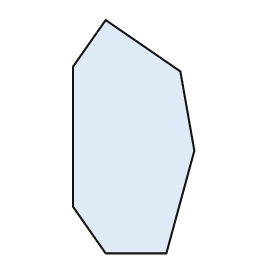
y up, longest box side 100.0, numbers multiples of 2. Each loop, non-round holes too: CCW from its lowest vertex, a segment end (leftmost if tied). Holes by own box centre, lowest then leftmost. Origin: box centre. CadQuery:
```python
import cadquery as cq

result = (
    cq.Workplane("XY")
    .moveTo(-12.0, -50.0)
    .lineTo(14.0, -50.0)
    .lineTo(26.0, -6.0)
    .lineTo(20.0, 28.0)
    .lineTo(-12.0, 50.0)
    .lineTo(-26.0, 30.0)
    .lineTo(-26.0, -30.0)
    .close()
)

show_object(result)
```